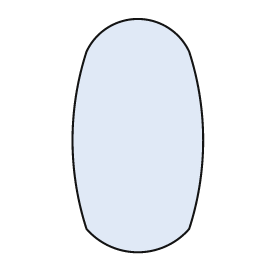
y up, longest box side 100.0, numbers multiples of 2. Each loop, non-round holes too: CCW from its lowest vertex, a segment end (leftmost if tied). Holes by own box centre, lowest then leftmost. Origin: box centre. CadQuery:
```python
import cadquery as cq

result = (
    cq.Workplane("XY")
    .moveTo(-22.0, -40.0)
    .threePointArc((0.0, -50.0), (22.0, -40.0))
    .threePointArc((28.0, -2.0), (22.0, 36.0))
    .threePointArc((0.0, 50.0), (-22.0, 36.0))
    .threePointArc((-28.0, -2.0), (-22.0, -40.0))
    .close()
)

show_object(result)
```